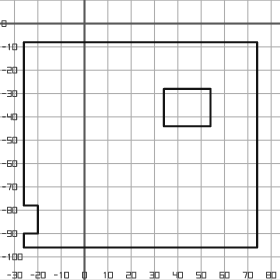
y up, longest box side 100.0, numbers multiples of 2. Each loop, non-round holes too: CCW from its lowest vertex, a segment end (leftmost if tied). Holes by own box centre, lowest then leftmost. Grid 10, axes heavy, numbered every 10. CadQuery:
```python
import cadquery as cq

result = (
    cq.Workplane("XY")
    .moveTo(-26.0, -96.0)
    .lineTo(74.0, -96.0)
    .lineTo(74.0, -8.0)
    .lineTo(-26.0, -8.0)
    .lineTo(-26.0, -78.0)
    .lineTo(-20.0, -78.0)
    .lineTo(-20.0, -90.0)
    .lineTo(-26.0, -90.0)
    .close()
    .moveTo(34.0, -44.0)
    .lineTo(54.0, -44.0)
    .lineTo(54.0, -28.0)
    .lineTo(34.0, -28.0)
    .close()
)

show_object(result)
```